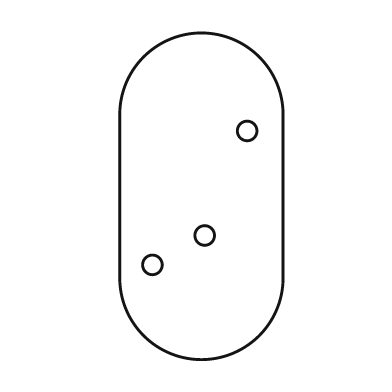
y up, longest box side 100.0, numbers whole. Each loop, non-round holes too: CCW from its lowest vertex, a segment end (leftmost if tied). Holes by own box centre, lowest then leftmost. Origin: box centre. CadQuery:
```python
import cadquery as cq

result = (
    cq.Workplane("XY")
    .moveTo(-25.0, -25.0)
    .threePointArc((0.0, -50.0), (25.0, -25.0))
    .lineTo(25.0, 25.0)
    .threePointArc((0.0, 50.0), (-25.0, 25.0))
    .close()
    .moveTo(-15.0, -21.0)
    .circle(3.0)
    .moveTo(1.0, -12.0)
    .circle(3.0)
    .moveTo(14.0, 20.0)
    .circle(3.0)
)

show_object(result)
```